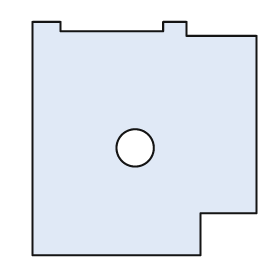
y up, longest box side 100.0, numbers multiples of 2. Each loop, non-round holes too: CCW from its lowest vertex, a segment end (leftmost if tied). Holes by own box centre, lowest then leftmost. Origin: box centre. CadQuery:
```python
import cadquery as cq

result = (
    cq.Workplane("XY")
    .moveTo(-48.0, -50.0)
    .lineTo(24.0, -50.0)
    .lineTo(24.0, -32.0)
    .lineTo(48.0, -32.0)
    .lineTo(48.0, 44.0)
    .lineTo(18.0, 44.0)
    .lineTo(18.0, 50.0)
    .lineTo(8.0, 50.0)
    .lineTo(8.0, 46.0)
    .lineTo(-36.0, 46.0)
    .lineTo(-36.0, 50.0)
    .lineTo(-48.0, 50.0)
    .close()
    .moveTo(-4.0, -4.0)
    .circle(8.0)
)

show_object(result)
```